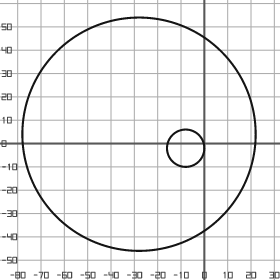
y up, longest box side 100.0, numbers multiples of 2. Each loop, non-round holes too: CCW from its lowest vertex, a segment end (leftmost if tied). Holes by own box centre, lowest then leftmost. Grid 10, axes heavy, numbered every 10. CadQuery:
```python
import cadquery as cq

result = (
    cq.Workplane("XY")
    .moveTo(-28.0, 4.0)
    .circle(50.0)
    .moveTo(-8.0, -2.0)
    .circle(8.0)
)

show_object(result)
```